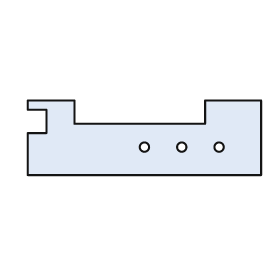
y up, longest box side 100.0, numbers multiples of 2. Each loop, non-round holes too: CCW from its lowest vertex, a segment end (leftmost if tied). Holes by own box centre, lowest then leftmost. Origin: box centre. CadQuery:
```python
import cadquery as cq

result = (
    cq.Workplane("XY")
    .moveTo(-50.0, -16.0)
    .lineTo(50.0, -16.0)
    .lineTo(50.0, 16.0)
    .lineTo(26.0, 16.0)
    .lineTo(26.0, 6.0)
    .lineTo(-30.0, 6.0)
    .lineTo(-30.0, 16.0)
    .lineTo(-50.0, 16.0)
    .lineTo(-50.0, 12.0)
    .lineTo(-42.0, 12.0)
    .lineTo(-42.0, 2.0)
    .lineTo(-50.0, 2.0)
    .close()
    .moveTo(0.0, -4.0)
    .circle(2.0)
    .moveTo(16.0, -4.0)
    .circle(2.0)
    .moveTo(32.0, -4.0)
    .circle(2.0)
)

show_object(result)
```